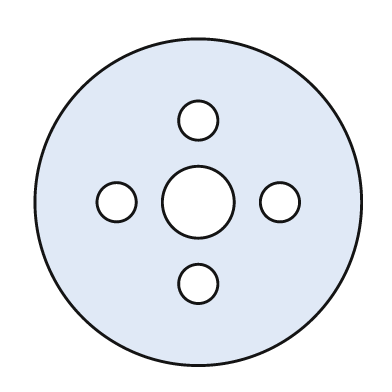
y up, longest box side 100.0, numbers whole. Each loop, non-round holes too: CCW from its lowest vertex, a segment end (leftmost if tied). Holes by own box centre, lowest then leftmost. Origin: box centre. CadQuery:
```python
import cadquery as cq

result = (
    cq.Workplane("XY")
    .moveTo(0.0, 0.0)
    .circle(50.0)
    .moveTo(0.0, -25.0)
    .circle(6.0)
    .moveTo(-25.0, 0.0)
    .circle(6.0)
    .moveTo(0.0, 0.0)
    .circle(11.0)
    .moveTo(25.0, 0.0)
    .circle(6.0)
    .moveTo(0.0, 25.0)
    .circle(6.0)
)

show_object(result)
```